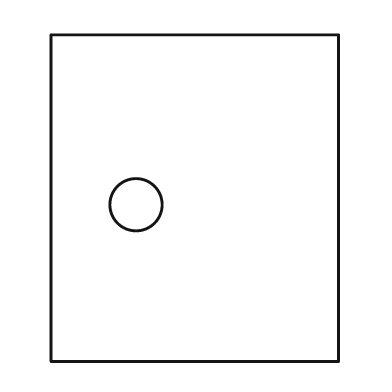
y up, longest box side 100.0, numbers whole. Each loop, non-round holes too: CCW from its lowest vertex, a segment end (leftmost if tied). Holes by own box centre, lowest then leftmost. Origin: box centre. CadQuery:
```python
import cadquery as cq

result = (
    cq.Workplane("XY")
    .moveTo(-44.0, -50.0)
    .lineTo(44.0, -50.0)
    .lineTo(44.0, 50.0)
    .lineTo(-44.0, 50.0)
    .close()
    .moveTo(-18.0, -2.0)
    .circle(8.0)
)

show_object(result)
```